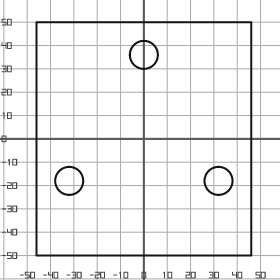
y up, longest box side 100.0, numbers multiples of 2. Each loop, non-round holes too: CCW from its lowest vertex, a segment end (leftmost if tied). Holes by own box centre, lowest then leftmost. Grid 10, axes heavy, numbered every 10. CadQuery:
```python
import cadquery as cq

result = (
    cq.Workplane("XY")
    .moveTo(-46.0, -50.0)
    .lineTo(46.0, -50.0)
    .lineTo(46.0, 50.0)
    .lineTo(-46.0, 50.0)
    .close()
    .moveTo(-32.0, -18.0)
    .circle(6.0)
    .moveTo(32.0, -18.0)
    .circle(6.0)
    .moveTo(0.0, 36.0)
    .circle(6.0)
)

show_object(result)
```